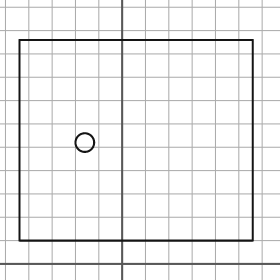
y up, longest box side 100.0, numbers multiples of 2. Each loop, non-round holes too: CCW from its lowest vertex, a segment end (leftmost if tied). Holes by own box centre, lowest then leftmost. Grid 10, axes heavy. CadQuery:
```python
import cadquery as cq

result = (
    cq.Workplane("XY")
    .moveTo(-44.0, 10.0)
    .lineTo(56.0, 10.0)
    .lineTo(56.0, 96.0)
    .lineTo(-44.0, 96.0)
    .close()
    .moveTo(-16.0, 52.0)
    .circle(4.0)
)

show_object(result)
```